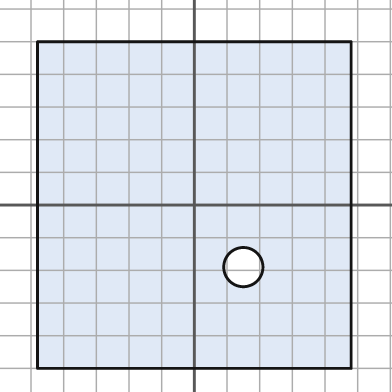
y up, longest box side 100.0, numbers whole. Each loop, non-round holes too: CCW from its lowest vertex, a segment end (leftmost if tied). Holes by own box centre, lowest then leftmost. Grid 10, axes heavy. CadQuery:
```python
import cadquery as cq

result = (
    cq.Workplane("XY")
    .moveTo(-48.0, -50.0)
    .lineTo(48.0, -50.0)
    .lineTo(48.0, 50.0)
    .lineTo(-48.0, 50.0)
    .close()
    .moveTo(15.0, -19.0)
    .circle(6.0)
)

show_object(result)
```